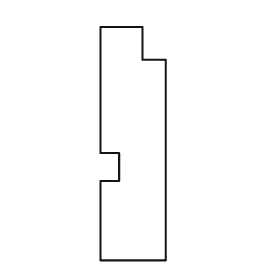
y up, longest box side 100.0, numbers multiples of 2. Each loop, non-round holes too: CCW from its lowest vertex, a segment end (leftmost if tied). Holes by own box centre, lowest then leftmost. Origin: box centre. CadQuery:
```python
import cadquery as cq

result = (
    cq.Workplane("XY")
    .moveTo(-14.0, -50.0)
    .lineTo(14.0, -50.0)
    .lineTo(14.0, 36.0)
    .lineTo(4.0, 36.0)
    .lineTo(4.0, 50.0)
    .lineTo(-14.0, 50.0)
    .lineTo(-14.0, -4.0)
    .lineTo(-6.0, -4.0)
    .lineTo(-6.0, -16.0)
    .lineTo(-14.0, -16.0)
    .close()
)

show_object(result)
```